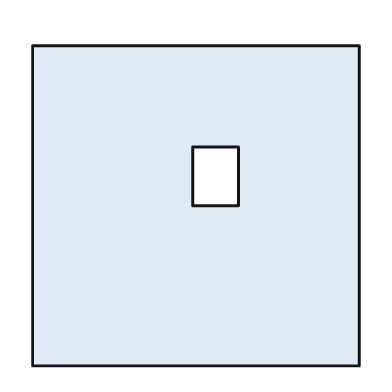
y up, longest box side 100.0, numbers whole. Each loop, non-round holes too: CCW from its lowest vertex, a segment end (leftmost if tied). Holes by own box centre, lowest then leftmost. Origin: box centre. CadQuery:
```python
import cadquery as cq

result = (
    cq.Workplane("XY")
    .moveTo(-50.0, -49.0)
    .lineTo(50.0, -49.0)
    .lineTo(50.0, 49.0)
    .lineTo(-50.0, 49.0)
    .close()
    .moveTo(-1.0, 0.0)
    .lineTo(13.0, 0.0)
    .lineTo(13.0, 18.0)
    .lineTo(-1.0, 18.0)
    .close()
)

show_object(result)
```